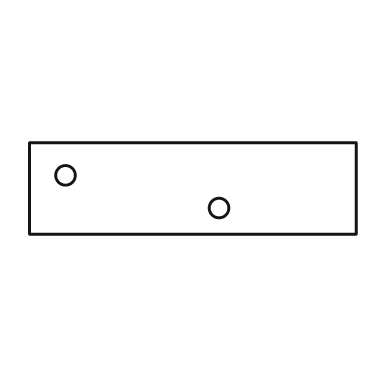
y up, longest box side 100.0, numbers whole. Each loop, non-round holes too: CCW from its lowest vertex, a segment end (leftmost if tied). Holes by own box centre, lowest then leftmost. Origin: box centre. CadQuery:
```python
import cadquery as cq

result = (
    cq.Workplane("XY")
    .moveTo(-50.0, -14.0)
    .lineTo(50.0, -14.0)
    .lineTo(50.0, 14.0)
    .lineTo(-50.0, 14.0)
    .close()
    .moveTo(8.0, -6.0)
    .circle(3.0)
    .moveTo(-39.0, 4.0)
    .circle(3.0)
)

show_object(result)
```